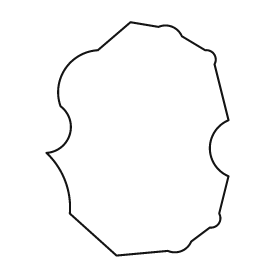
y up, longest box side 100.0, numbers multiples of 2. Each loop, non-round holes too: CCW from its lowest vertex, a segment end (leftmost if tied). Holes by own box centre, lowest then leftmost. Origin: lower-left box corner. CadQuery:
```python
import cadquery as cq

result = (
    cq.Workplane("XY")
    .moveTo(30.0, 0.0)
    .lineTo(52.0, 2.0)
    .threePointArc((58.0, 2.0), (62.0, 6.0))
    .lineTo(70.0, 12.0)
    .threePointArc((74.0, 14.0), (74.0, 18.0))
    .lineTo(78.0, 34.0)
    .threePointArc((70.0, 46.0), (78.0, 58.0))
    .lineTo(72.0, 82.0)
    .threePointArc((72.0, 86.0), (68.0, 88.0))
    .lineTo(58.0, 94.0)
    .threePointArc((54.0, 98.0), (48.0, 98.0))
    .lineTo(36.0, 100.0)
    .lineTo(22.0, 88.0)
    .threePointArc((8.0, 80.0), (6.0, 64.0))
    .threePointArc((10.0, 52.0), (0.0, 44.0))
    .threePointArc((8.0, 32.0), (10.0, 18.0))
    .close()
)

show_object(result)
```